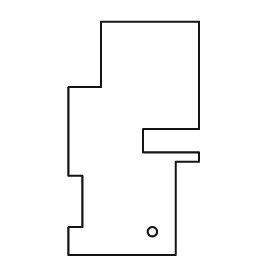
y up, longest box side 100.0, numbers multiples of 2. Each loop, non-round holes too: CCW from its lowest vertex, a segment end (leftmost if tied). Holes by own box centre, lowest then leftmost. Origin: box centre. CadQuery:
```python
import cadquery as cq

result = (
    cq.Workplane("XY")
    .moveTo(-28.0, -50.0)
    .lineTo(18.0, -50.0)
    .lineTo(18.0, -10.0)
    .lineTo(28.0, -10.0)
    .lineTo(28.0, -6.0)
    .lineTo(4.0, -6.0)
    .lineTo(4.0, 4.0)
    .lineTo(28.0, 4.0)
    .lineTo(28.0, 50.0)
    .lineTo(-14.0, 50.0)
    .lineTo(-14.0, 22.0)
    .lineTo(-28.0, 22.0)
    .lineTo(-28.0, -16.0)
    .lineTo(-22.0, -16.0)
    .lineTo(-22.0, -38.0)
    .lineTo(-28.0, -38.0)
    .close()
    .moveTo(8.0, -40.0)
    .circle(2.0)
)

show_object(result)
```